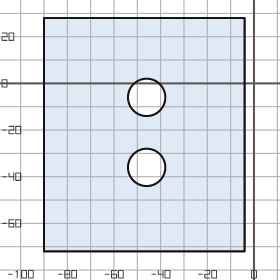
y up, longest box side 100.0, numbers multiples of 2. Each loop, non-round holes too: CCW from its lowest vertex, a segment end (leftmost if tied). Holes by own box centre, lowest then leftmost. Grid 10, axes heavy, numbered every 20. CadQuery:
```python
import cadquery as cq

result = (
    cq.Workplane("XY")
    .moveTo(-90.0, -72.0)
    .lineTo(-4.0, -72.0)
    .lineTo(-4.0, 28.0)
    .lineTo(-90.0, 28.0)
    .close()
    .moveTo(-46.0, -36.0)
    .circle(8.0)
    .moveTo(-46.0, -6.0)
    .circle(8.0)
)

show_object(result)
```